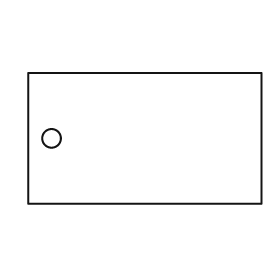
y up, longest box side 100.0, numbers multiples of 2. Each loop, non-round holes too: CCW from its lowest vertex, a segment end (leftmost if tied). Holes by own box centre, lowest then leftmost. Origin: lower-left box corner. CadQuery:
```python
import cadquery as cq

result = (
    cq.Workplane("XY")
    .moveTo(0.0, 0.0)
    .lineTo(100.0, 0.0)
    .lineTo(100.0, 56.0)
    .lineTo(0.0, 56.0)
    .close()
    .moveTo(10.0, 28.0)
    .circle(4.0)
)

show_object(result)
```